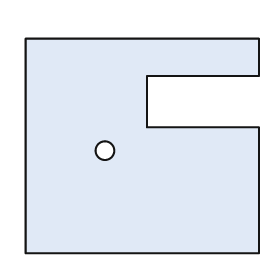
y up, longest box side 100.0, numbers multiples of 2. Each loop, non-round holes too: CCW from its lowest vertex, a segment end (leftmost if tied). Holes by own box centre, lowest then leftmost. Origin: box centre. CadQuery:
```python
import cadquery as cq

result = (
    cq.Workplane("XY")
    .moveTo(-50.0, -46.0)
    .lineTo(50.0, -46.0)
    .lineTo(50.0, 8.0)
    .lineTo(2.0, 8.0)
    .lineTo(2.0, 30.0)
    .lineTo(50.0, 30.0)
    .lineTo(50.0, 46.0)
    .lineTo(-50.0, 46.0)
    .close()
    .moveTo(-16.0, -2.0)
    .circle(4.0)
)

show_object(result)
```